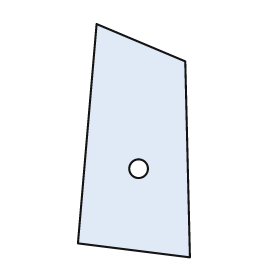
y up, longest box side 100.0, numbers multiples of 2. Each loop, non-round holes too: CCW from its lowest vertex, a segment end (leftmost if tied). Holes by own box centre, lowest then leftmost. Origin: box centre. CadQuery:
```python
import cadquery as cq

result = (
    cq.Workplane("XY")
    .moveTo(24.0, -50.0)
    .lineTo(22.0, 34.0)
    .lineTo(-16.0, 50.0)
    .lineTo(-24.0, -44.0)
    .close()
    .moveTo(2.0, -12.0)
    .circle(4.0)
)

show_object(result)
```